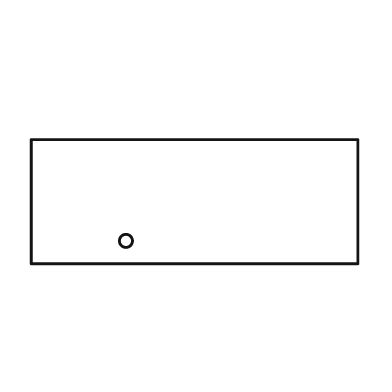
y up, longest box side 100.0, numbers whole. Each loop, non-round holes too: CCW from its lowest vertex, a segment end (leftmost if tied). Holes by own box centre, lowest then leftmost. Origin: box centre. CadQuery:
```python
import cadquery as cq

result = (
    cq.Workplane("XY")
    .moveTo(-50.0, -19.0)
    .lineTo(50.0, -19.0)
    .lineTo(50.0, 19.0)
    .lineTo(-50.0, 19.0)
    .close()
    .moveTo(-21.0, -12.0)
    .circle(2.0)
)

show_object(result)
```